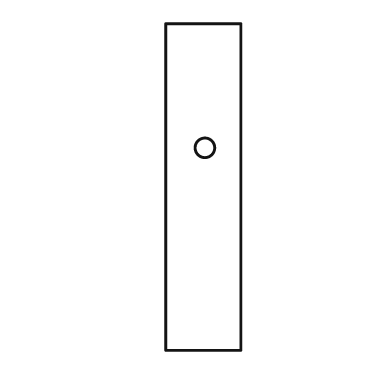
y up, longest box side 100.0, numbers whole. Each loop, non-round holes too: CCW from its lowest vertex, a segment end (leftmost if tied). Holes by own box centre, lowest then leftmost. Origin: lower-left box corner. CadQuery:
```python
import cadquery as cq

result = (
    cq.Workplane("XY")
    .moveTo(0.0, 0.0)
    .lineTo(23.0, 0.0)
    .lineTo(23.0, 100.0)
    .lineTo(0.0, 100.0)
    .close()
    .moveTo(12.0, 62.0)
    .circle(3.0)
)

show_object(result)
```